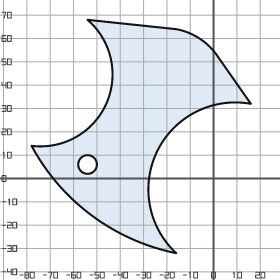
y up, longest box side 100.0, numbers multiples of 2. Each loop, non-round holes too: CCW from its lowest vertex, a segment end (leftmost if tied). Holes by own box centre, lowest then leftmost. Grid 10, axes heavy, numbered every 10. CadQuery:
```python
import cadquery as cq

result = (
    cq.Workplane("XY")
    .moveTo(-16.0, -32.0)
    .threePointArc((-24.0, 12.0), (16.0, 32.0))
    .lineTo(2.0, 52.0)
    .threePointArc((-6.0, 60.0), (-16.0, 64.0))
    .lineTo(-54.0, 68.0)
    .threePointArc((-46.0, 32.0), (-78.0, 14.0))
    .threePointArc((-52.0, -16.0), (-16.0, -32.0))
    .close()
    .moveTo(-54.0, 6.0)
    .circle(4.0)
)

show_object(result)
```